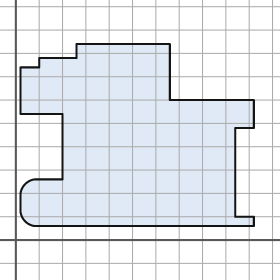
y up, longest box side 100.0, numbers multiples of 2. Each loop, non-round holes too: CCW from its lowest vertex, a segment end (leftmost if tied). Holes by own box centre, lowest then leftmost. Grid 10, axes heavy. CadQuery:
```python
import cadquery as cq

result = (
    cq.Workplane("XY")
    .moveTo(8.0, 6.0)
    .lineTo(102.0, 6.0)
    .lineTo(102.0, 10.0)
    .lineTo(94.0, 10.0)
    .lineTo(94.0, 48.0)
    .lineTo(102.0, 48.0)
    .lineTo(102.0, 60.0)
    .lineTo(66.0, 60.0)
    .lineTo(66.0, 84.0)
    .lineTo(26.0, 84.0)
    .lineTo(26.0, 78.0)
    .lineTo(10.0, 78.0)
    .lineTo(10.0, 74.0)
    .lineTo(2.0, 74.0)
    .lineTo(2.0, 54.0)
    .lineTo(20.0, 54.0)
    .lineTo(20.0, 26.0)
    .lineTo(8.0, 26.0)
    .threePointArc((4.0, 24.0), (2.0, 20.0))
    .lineTo(2.0, 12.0)
    .threePointArc((4.0, 8.0), (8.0, 6.0))
    .close()
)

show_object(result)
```